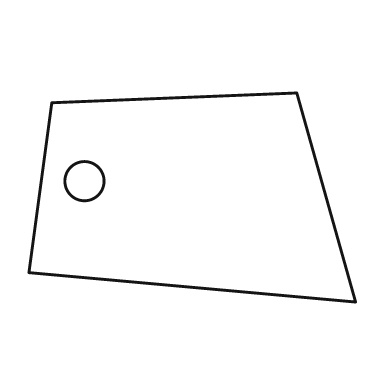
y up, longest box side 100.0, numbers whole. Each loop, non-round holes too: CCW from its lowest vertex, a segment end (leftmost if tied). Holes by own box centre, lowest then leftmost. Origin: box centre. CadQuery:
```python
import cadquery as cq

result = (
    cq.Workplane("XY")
    .moveTo(50.0, -32.0)
    .lineTo(32.0, 32.0)
    .lineTo(-43.0, 29.0)
    .lineTo(-50.0, -23.0)
    .close()
    .moveTo(-33.0, 5.0)
    .circle(6.0)
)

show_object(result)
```